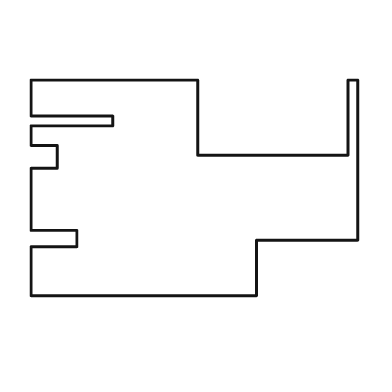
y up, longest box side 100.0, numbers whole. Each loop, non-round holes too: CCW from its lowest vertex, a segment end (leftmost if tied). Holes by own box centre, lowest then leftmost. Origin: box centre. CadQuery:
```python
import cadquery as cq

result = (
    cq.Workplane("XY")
    .moveTo(-50.0, -33.0)
    .lineTo(19.0, -33.0)
    .lineTo(19.0, -16.0)
    .lineTo(50.0, -16.0)
    .lineTo(50.0, 33.0)
    .lineTo(47.0, 33.0)
    .lineTo(47.0, 10.0)
    .lineTo(1.0, 10.0)
    .lineTo(1.0, 33.0)
    .lineTo(-50.0, 33.0)
    .lineTo(-50.0, 22.0)
    .lineTo(-25.0, 22.0)
    .lineTo(-25.0, 19.0)
    .lineTo(-50.0, 19.0)
    .lineTo(-50.0, 13.0)
    .lineTo(-42.0, 13.0)
    .lineTo(-42.0, 6.0)
    .lineTo(-50.0, 6.0)
    .lineTo(-50.0, -13.0)
    .lineTo(-36.0, -13.0)
    .lineTo(-36.0, -18.0)
    .lineTo(-50.0, -18.0)
    .close()
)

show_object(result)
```